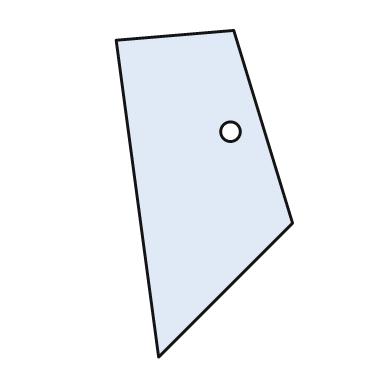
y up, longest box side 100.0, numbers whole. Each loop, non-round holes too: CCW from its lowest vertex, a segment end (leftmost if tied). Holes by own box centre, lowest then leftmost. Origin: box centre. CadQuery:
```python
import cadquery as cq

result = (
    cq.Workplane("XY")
    .moveTo(-14.0, -50.0)
    .lineTo(27.0, -9.0)
    .lineTo(9.0, 50.0)
    .lineTo(-27.0, 47.0)
    .close()
    .moveTo(8.0, 19.0)
    .circle(3.0)
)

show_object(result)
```